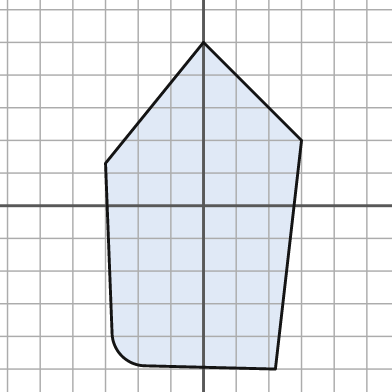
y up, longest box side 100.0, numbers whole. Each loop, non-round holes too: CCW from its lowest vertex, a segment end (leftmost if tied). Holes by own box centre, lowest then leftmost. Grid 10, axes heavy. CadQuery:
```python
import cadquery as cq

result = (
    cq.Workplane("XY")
    .moveTo(22.0, -50.0)
    .lineTo(30.0, 20.0)
    .lineTo(0.0, 50.0)
    .lineTo(-30.0, 13.0)
    .lineTo(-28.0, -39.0)
    .threePointArc((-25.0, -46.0), (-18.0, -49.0))
    .close()
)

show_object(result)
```